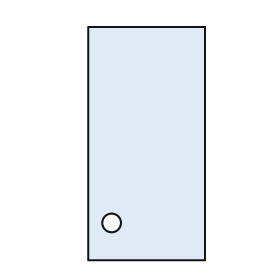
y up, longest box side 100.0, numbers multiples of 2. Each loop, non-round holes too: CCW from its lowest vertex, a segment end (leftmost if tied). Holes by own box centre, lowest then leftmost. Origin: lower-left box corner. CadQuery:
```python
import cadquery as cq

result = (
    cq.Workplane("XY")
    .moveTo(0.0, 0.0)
    .lineTo(50.0, 0.0)
    .lineTo(50.0, 100.0)
    .lineTo(0.0, 100.0)
    .close()
    .moveTo(10.0, 16.0)
    .circle(4.0)
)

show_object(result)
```